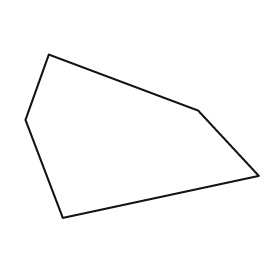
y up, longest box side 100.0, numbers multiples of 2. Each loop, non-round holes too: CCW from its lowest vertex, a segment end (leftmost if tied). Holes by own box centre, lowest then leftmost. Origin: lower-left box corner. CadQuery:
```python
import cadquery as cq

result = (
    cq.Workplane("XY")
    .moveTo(16.0, 0.0)
    .lineTo(100.0, 18.0)
    .lineTo(74.0, 46.0)
    .lineTo(10.0, 70.0)
    .lineTo(0.0, 42.0)
    .close()
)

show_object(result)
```